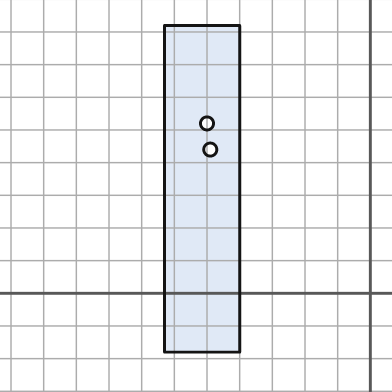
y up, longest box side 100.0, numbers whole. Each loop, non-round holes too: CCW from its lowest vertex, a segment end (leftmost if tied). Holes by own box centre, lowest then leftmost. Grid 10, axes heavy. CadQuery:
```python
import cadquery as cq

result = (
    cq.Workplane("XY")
    .moveTo(-63.0, -18.0)
    .lineTo(-40.0, -18.0)
    .lineTo(-40.0, 82.0)
    .lineTo(-63.0, 82.0)
    .close()
    .moveTo(-49.0, 44.0)
    .circle(2.0)
    .moveTo(-50.0, 52.0)
    .circle(2.0)
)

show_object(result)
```